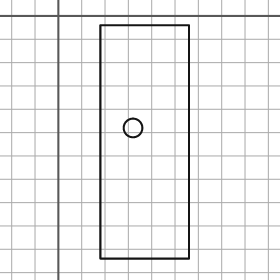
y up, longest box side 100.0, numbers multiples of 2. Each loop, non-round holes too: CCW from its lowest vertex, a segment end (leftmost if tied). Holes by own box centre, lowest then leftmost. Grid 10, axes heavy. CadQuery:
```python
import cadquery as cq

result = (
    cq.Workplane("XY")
    .moveTo(18.0, -104.0)
    .lineTo(56.0, -104.0)
    .lineTo(56.0, -4.0)
    .lineTo(18.0, -4.0)
    .close()
    .moveTo(32.0, -48.0)
    .circle(4.0)
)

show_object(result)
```